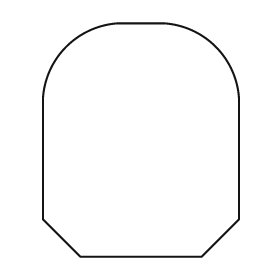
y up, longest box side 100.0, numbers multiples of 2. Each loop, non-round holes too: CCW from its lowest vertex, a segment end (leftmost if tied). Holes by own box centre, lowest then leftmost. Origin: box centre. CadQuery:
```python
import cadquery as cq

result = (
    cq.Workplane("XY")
    .moveTo(-26.0, -50.0)
    .lineTo(26.0, -50.0)
    .lineTo(42.0, -34.0)
    .lineTo(42.0, 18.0)
    .threePointArc((32.0, 40.0), (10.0, 50.0))
    .lineTo(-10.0, 50.0)
    .threePointArc((-32.0, 40.0), (-42.0, 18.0))
    .lineTo(-42.0, -34.0)
    .close()
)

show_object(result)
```